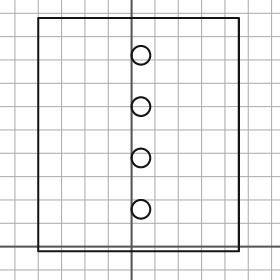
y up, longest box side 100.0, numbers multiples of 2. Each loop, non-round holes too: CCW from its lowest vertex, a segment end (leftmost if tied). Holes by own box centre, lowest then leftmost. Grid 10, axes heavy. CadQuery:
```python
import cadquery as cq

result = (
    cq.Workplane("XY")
    .moveTo(-40.0, -2.0)
    .lineTo(46.0, -2.0)
    .lineTo(46.0, 98.0)
    .lineTo(-40.0, 98.0)
    .close()
    .moveTo(4.0, 16.0)
    .circle(4.0)
    .moveTo(4.0, 38.0)
    .circle(4.0)
    .moveTo(4.0, 60.0)
    .circle(4.0)
    .moveTo(4.0, 82.0)
    .circle(4.0)
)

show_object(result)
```